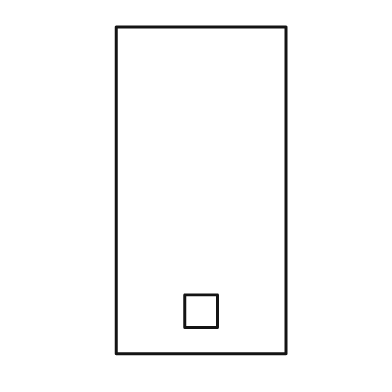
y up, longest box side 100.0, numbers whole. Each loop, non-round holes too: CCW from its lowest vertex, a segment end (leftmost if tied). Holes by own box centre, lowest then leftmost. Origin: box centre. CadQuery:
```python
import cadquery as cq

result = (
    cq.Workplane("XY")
    .moveTo(-26.0, -50.0)
    .lineTo(26.0, -50.0)
    .lineTo(26.0, 50.0)
    .lineTo(-26.0, 50.0)
    .close()
    .moveTo(-5.0, -42.0)
    .lineTo(5.0, -42.0)
    .lineTo(5.0, -32.0)
    .lineTo(-5.0, -32.0)
    .close()
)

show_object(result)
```